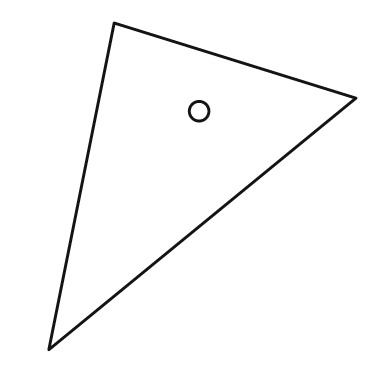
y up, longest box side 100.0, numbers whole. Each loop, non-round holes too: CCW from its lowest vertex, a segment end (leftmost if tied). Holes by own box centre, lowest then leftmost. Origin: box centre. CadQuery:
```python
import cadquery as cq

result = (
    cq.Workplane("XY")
    .moveTo(-47.0, -50.0)
    .lineTo(47.0, 27.0)
    .lineTo(-27.0, 50.0)
    .close()
    .moveTo(-1.0, 23.0)
    .circle(3.0)
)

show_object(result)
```